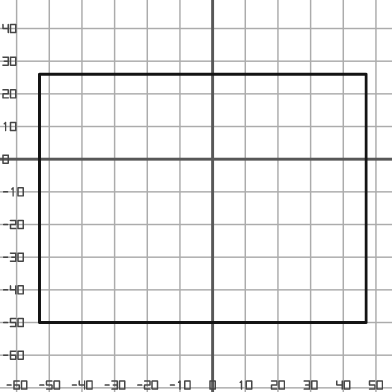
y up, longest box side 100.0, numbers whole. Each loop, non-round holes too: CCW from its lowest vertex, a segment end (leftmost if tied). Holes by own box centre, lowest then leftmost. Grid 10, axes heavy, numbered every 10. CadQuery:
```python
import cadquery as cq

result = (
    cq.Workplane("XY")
    .moveTo(-53.0, -50.0)
    .lineTo(47.0, -50.0)
    .lineTo(47.0, 26.0)
    .lineTo(-53.0, 26.0)
    .close()
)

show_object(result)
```